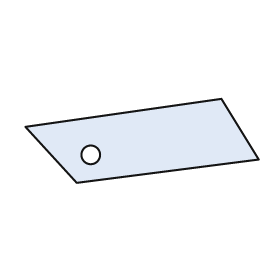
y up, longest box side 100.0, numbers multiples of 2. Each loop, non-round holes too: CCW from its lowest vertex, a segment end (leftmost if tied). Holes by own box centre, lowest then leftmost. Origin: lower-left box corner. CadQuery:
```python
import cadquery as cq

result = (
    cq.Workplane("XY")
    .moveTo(22.0, 0.0)
    .lineTo(100.0, 10.0)
    .lineTo(84.0, 36.0)
    .lineTo(0.0, 24.0)
    .close()
    .moveTo(28.0, 12.0)
    .circle(4.0)
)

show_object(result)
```